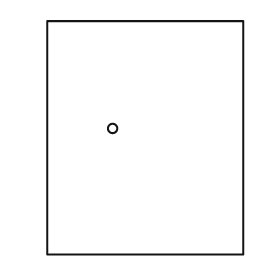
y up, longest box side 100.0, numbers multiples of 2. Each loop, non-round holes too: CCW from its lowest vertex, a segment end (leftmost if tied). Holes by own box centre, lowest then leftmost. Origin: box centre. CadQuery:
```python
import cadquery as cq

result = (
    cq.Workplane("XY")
    .moveTo(-42.0, -50.0)
    .lineTo(42.0, -50.0)
    .lineTo(42.0, 50.0)
    .lineTo(-42.0, 50.0)
    .close()
    .moveTo(-14.0, 4.0)
    .circle(2.0)
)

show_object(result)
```